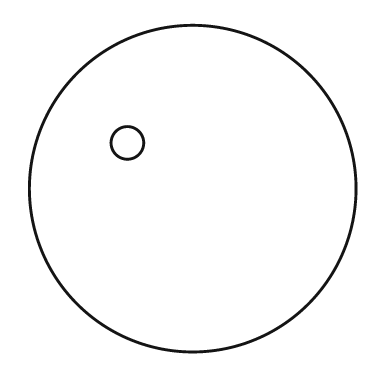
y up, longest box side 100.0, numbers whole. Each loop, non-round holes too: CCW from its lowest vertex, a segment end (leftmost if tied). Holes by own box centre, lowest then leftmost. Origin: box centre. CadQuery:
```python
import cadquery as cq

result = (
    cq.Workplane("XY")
    .moveTo(0.0, 0.0)
    .circle(50.0)
    .moveTo(-20.0, 14.0)
    .circle(5.0)
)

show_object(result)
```